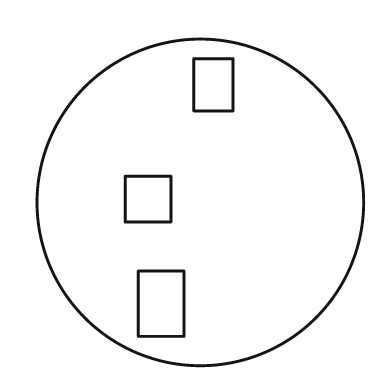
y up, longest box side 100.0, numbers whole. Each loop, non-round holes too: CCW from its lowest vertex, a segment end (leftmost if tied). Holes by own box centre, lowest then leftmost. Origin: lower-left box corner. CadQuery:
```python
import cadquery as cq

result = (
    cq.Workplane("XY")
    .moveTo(50.0, 50.0)
    .circle(50.0)
    .moveTo(31.0, 9.0)
    .lineTo(45.0, 9.0)
    .lineTo(45.0, 29.0)
    .lineTo(31.0, 29.0)
    .close()
    .moveTo(27.0, 44.0)
    .lineTo(41.0, 44.0)
    .lineTo(41.0, 58.0)
    .lineTo(27.0, 58.0)
    .close()
    .moveTo(48.0, 78.0)
    .lineTo(60.0, 78.0)
    .lineTo(60.0, 94.0)
    .lineTo(48.0, 94.0)
    .close()
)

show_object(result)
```